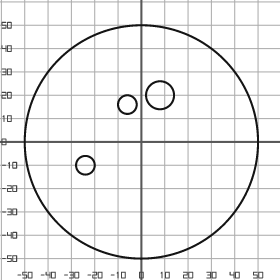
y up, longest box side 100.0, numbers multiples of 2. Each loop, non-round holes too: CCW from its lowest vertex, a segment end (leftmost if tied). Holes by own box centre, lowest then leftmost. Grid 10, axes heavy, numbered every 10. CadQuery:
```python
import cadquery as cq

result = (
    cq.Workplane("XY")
    .moveTo(0.0, 0.0)
    .circle(50.0)
    .moveTo(-24.0, -10.0)
    .circle(4.0)
    .moveTo(-6.0, 16.0)
    .circle(4.0)
    .moveTo(8.0, 20.0)
    .circle(6.0)
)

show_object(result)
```